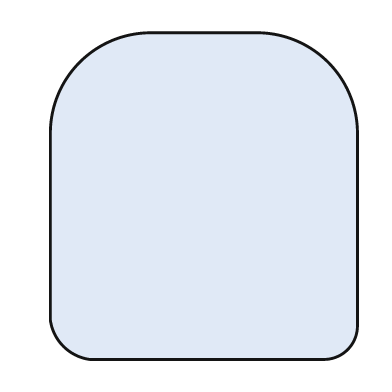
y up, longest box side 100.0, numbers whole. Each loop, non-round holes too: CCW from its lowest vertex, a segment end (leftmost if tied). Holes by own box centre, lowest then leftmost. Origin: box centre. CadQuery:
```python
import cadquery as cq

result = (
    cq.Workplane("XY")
    .moveTo(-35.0, -50.0)
    .lineTo(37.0, -50.0)
    .threePointArc((44.0, -47.0), (47.0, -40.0))
    .lineTo(47.0, 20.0)
    .threePointArc((38.0, 41.0), (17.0, 50.0))
    .lineTo(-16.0, 50.0)
    .threePointArc((-38.0, 41.0), (-47.0, 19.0))
    .lineTo(-47.0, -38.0)
    .threePointArc((-43.0, -46.0), (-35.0, -50.0))
    .close()
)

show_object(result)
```